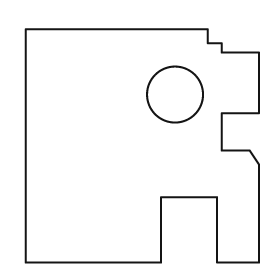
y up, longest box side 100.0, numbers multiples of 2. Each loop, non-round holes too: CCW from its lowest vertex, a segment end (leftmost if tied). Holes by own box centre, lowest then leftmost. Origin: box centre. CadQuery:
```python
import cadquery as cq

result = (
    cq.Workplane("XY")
    .moveTo(-50.0, -50.0)
    .lineTo(8.0, -50.0)
    .lineTo(8.0, -22.0)
    .lineTo(32.0, -22.0)
    .lineTo(32.0, -50.0)
    .lineTo(50.0, -50.0)
    .lineTo(50.0, -8.0)
    .lineTo(46.0, -2.0)
    .lineTo(34.0, -2.0)
    .lineTo(34.0, 14.0)
    .lineTo(50.0, 14.0)
    .lineTo(50.0, 40.0)
    .lineTo(34.0, 40.0)
    .lineTo(34.0, 44.0)
    .lineTo(28.0, 44.0)
    .lineTo(28.0, 50.0)
    .lineTo(-50.0, 50.0)
    .close()
    .moveTo(14.0, 22.0)
    .circle(12.0)
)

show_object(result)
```